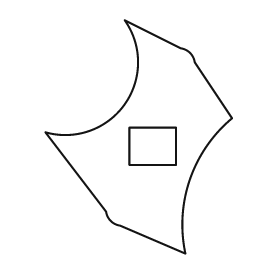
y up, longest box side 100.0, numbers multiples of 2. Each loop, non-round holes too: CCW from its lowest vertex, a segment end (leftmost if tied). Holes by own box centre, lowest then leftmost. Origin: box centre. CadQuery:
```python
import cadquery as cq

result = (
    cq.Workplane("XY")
    .moveTo(20.0, -50.0)
    .threePointArc((22.0, -18.0), (40.0, 8.0))
    .lineTo(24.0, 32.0)
    .threePointArc((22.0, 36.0), (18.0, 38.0))
    .lineTo(-6.0, 50.0)
    .threePointArc((-6.0, 14.0), (-40.0, 2.0))
    .lineTo(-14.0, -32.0)
    .threePointArc((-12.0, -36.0), (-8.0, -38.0))
    .close()
    .moveTo(-4.0, -12.0)
    .lineTo(16.0, -12.0)
    .lineTo(16.0, 4.0)
    .lineTo(-4.0, 4.0)
    .close()
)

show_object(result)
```